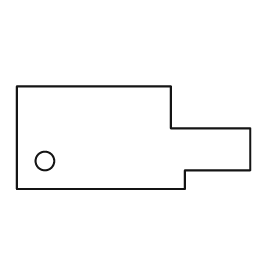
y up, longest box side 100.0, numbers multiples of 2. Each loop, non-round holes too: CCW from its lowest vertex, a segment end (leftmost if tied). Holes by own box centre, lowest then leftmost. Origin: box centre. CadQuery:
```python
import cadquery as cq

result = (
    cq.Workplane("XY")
    .moveTo(-50.0, -22.0)
    .lineTo(22.0, -22.0)
    .lineTo(22.0, -14.0)
    .lineTo(50.0, -14.0)
    .lineTo(50.0, 4.0)
    .lineTo(16.0, 4.0)
    .lineTo(16.0, 22.0)
    .lineTo(-50.0, 22.0)
    .close()
    .moveTo(-38.0, -10.0)
    .circle(4.0)
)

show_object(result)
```